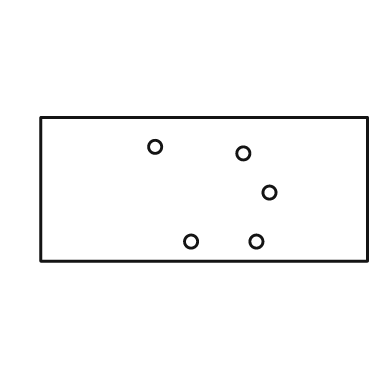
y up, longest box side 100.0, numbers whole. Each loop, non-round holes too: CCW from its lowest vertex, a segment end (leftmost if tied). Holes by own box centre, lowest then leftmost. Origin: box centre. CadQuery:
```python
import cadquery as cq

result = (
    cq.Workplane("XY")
    .moveTo(-50.0, -22.0)
    .lineTo(50.0, -22.0)
    .lineTo(50.0, 22.0)
    .lineTo(-50.0, 22.0)
    .close()
    .moveTo(-4.0, -16.0)
    .circle(2.0)
    .moveTo(16.0, -16.0)
    .circle(2.0)
    .moveTo(20.0, -1.0)
    .circle(2.0)
    .moveTo(12.0, 11.0)
    .circle(2.0)
    .moveTo(-15.0, 13.0)
    .circle(2.0)
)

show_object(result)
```